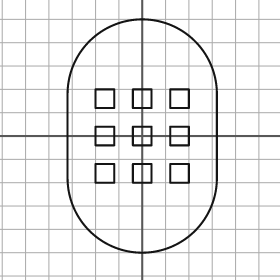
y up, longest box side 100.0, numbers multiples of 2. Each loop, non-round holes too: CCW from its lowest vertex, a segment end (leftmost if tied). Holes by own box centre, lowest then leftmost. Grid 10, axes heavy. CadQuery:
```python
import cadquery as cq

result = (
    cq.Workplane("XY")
    .moveTo(-32.0, -18.0)
    .threePointArc((0.0, -50.0), (32.0, -18.0))
    .lineTo(32.0, 18.0)
    .threePointArc((0.0, 50.0), (-32.0, 18.0))
    .close()
    .moveTo(-20.0, -20.0)
    .lineTo(-12.0, -20.0)
    .lineTo(-12.0, -12.0)
    .lineTo(-20.0, -12.0)
    .close()
    .moveTo(-4.0, -20.0)
    .lineTo(4.0, -20.0)
    .lineTo(4.0, -12.0)
    .lineTo(-4.0, -12.0)
    .close()
    .moveTo(12.0, -20.0)
    .lineTo(20.0, -20.0)
    .lineTo(20.0, -12.0)
    .lineTo(12.0, -12.0)
    .close()
    .moveTo(-20.0, -4.0)
    .lineTo(-12.0, -4.0)
    .lineTo(-12.0, 4.0)
    .lineTo(-20.0, 4.0)
    .close()
    .moveTo(-4.0, -4.0)
    .lineTo(4.0, -4.0)
    .lineTo(4.0, 4.0)
    .lineTo(-4.0, 4.0)
    .close()
    .moveTo(12.0, -4.0)
    .lineTo(20.0, -4.0)
    .lineTo(20.0, 4.0)
    .lineTo(12.0, 4.0)
    .close()
    .moveTo(-20.0, 12.0)
    .lineTo(-12.0, 12.0)
    .lineTo(-12.0, 20.0)
    .lineTo(-20.0, 20.0)
    .close()
    .moveTo(-4.0, 12.0)
    .lineTo(4.0, 12.0)
    .lineTo(4.0, 20.0)
    .lineTo(-4.0, 20.0)
    .close()
    .moveTo(12.0, 12.0)
    .lineTo(20.0, 12.0)
    .lineTo(20.0, 20.0)
    .lineTo(12.0, 20.0)
    .close()
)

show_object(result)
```